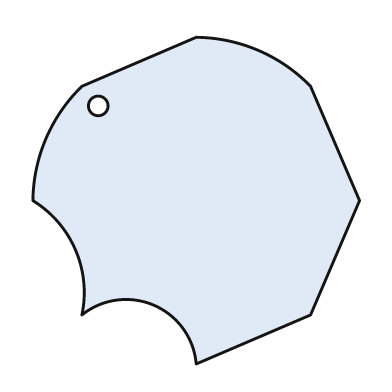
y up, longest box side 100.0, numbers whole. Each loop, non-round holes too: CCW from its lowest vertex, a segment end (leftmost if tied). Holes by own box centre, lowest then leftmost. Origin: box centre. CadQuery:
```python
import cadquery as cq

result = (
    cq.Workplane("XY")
    .moveTo(0.0, -50.0)
    .lineTo(35.0, -35.0)
    .lineTo(50.0, 0.0)
    .lineTo(35.0, 35.0)
    .threePointArc((19.0, 46.0), (0.0, 50.0))
    .lineTo(-35.0, 35.0)
    .threePointArc((-46.0, 19.0), (-50.0, 0.0))
    .threePointArc((-37.0, -15.0), (-35.0, -35.0))
    .threePointArc((-13.0, -32.0), (0.0, -50.0))
    .close()
    .moveTo(-30.0, 29.0)
    .circle(3.0)
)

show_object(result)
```